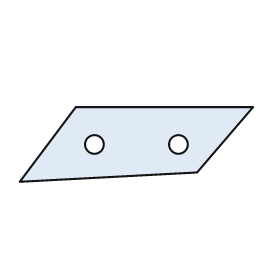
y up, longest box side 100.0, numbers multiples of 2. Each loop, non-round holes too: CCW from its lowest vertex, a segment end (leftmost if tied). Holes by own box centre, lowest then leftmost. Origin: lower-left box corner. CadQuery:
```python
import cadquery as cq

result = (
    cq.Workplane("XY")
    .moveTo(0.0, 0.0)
    .lineTo(76.0, 4.0)
    .lineTo(100.0, 32.0)
    .lineTo(24.0, 32.0)
    .close()
    .moveTo(32.0, 16.0)
    .circle(4.0)
    .moveTo(68.0, 16.0)
    .circle(4.0)
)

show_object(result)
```